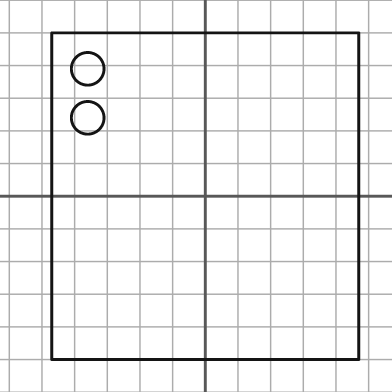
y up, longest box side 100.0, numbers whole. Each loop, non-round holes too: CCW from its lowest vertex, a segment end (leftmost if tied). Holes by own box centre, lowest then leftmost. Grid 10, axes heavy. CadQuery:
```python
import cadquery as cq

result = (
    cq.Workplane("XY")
    .moveTo(-47.0, -50.0)
    .lineTo(47.0, -50.0)
    .lineTo(47.0, 50.0)
    .lineTo(-47.0, 50.0)
    .close()
    .moveTo(-36.0, 24.0)
    .circle(5.0)
    .moveTo(-36.0, 39.0)
    .circle(5.0)
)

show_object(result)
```